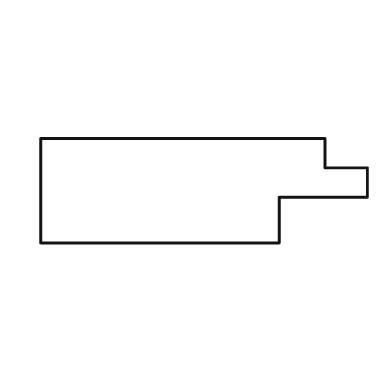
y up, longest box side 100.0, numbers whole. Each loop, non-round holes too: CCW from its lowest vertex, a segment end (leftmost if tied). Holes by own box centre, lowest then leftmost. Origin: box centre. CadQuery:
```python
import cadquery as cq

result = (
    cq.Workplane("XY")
    .moveTo(-50.0, -16.0)
    .lineTo(23.0, -16.0)
    .lineTo(23.0, -2.0)
    .lineTo(50.0, -2.0)
    .lineTo(50.0, 7.0)
    .lineTo(37.0, 7.0)
    .lineTo(37.0, 16.0)
    .lineTo(-50.0, 16.0)
    .close()
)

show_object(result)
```